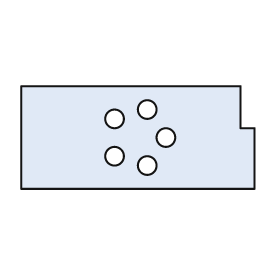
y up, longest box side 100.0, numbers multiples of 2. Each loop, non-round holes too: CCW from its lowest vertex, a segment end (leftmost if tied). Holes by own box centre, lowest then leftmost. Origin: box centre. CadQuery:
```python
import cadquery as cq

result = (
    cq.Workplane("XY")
    .moveTo(-50.0, -22.0)
    .lineTo(50.0, -22.0)
    .lineTo(50.0, 4.0)
    .lineTo(44.0, 4.0)
    .lineTo(44.0, 22.0)
    .lineTo(-50.0, 22.0)
    .close()
    .moveTo(4.0, -12.0)
    .circle(4.0)
    .moveTo(-10.0, -8.0)
    .circle(4.0)
    .moveTo(12.0, 0.0)
    .circle(4.0)
    .moveTo(-10.0, 8.0)
    .circle(4.0)
    .moveTo(4.0, 12.0)
    .circle(4.0)
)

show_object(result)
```